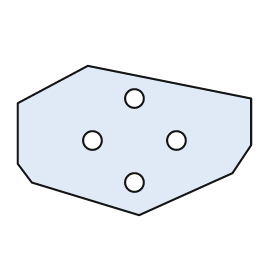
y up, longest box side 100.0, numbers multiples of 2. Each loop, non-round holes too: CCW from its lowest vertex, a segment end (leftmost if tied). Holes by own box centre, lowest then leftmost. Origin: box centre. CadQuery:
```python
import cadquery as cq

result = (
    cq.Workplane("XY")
    .moveTo(2.0, -32.0)
    .lineTo(42.0, -14.0)
    .lineTo(50.0, -2.0)
    .lineTo(50.0, 18.0)
    .lineTo(-20.0, 32.0)
    .lineTo(-50.0, 16.0)
    .lineTo(-50.0, -10.0)
    .lineTo(-44.0, -18.0)
    .close()
    .moveTo(0.0, -18.0)
    .circle(4.0)
    .moveTo(-18.0, 0.0)
    .circle(4.0)
    .moveTo(18.0, 0.0)
    .circle(4.0)
    .moveTo(0.0, 18.0)
    .circle(4.0)
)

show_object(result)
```